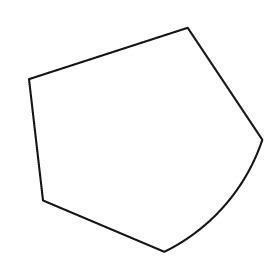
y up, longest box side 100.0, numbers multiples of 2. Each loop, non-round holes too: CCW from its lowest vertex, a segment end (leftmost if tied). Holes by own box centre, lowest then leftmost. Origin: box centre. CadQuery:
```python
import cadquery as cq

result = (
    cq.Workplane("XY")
    .moveTo(8.0, -48.0)
    .threePointArc((34.0, -28.0), (50.0, 0.0))
    .lineTo(18.0, 48.0)
    .lineTo(-50.0, 26.0)
    .lineTo(-44.0, -26.0)
    .close()
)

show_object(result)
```